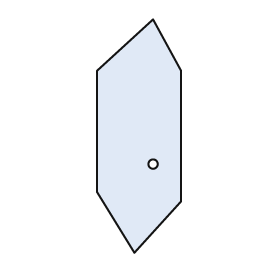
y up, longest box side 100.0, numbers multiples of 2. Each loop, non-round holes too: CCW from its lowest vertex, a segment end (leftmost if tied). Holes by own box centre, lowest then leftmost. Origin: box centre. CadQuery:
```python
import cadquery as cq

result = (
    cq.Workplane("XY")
    .moveTo(-2.0, -50.0)
    .lineTo(18.0, -28.0)
    .lineTo(18.0, 28.0)
    .lineTo(6.0, 50.0)
    .lineTo(-18.0, 28.0)
    .lineTo(-18.0, -24.0)
    .close()
    .moveTo(6.0, -12.0)
    .circle(2.0)
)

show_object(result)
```